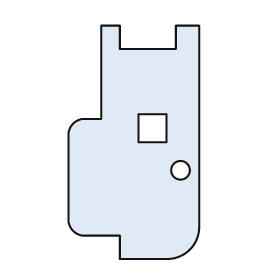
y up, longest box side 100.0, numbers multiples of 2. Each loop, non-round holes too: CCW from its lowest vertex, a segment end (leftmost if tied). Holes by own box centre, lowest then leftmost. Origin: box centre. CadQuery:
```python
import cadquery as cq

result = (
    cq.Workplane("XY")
    .moveTo(-6.0, -50.0)
    .lineTo(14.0, -50.0)
    .threePointArc((24.0, -46.0), (28.0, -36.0))
    .lineTo(28.0, 50.0)
    .lineTo(18.0, 50.0)
    .lineTo(18.0, 40.0)
    .lineTo(-6.0, 40.0)
    .lineTo(-6.0, 50.0)
    .lineTo(-14.0, 50.0)
    .lineTo(-14.0, 10.0)
    .lineTo(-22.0, 10.0)
    .threePointArc((-26.0, 8.0), (-28.0, 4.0))
    .lineTo(-28.0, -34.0)
    .threePointArc((-26.0, -38.0), (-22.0, -40.0))
    .lineTo(-6.0, -40.0)
    .close()
    .moveTo(20.0, -12.0)
    .circle(4.0)
    .moveTo(2.0, 0.0)
    .lineTo(14.0, 0.0)
    .lineTo(14.0, 12.0)
    .lineTo(2.0, 12.0)
    .close()
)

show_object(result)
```